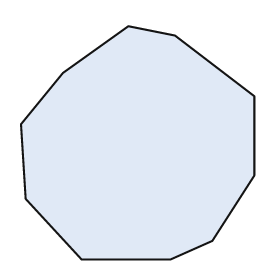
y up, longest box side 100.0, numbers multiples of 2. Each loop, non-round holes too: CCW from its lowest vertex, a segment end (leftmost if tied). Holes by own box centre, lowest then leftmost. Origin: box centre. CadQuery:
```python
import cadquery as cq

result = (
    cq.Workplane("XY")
    .moveTo(-24.0, -50.0)
    .lineTo(14.0, -50.0)
    .lineTo(32.0, -42.0)
    .lineTo(50.0, -14.0)
    .lineTo(50.0, 20.0)
    .lineTo(16.0, 46.0)
    .lineTo(-4.0, 50.0)
    .lineTo(-32.0, 30.0)
    .lineTo(-50.0, 8.0)
    .lineTo(-48.0, -24.0)
    .close()
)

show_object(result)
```